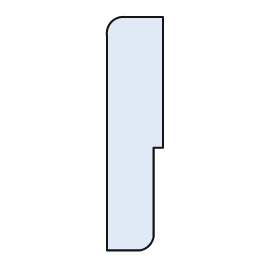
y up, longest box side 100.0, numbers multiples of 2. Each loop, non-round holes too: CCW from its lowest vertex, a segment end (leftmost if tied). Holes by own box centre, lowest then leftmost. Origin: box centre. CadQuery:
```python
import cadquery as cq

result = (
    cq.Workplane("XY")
    .moveTo(-12.0, -50.0)
    .lineTo(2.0, -50.0)
    .threePointArc((6.0, -48.0), (8.0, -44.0))
    .lineTo(8.0, -6.0)
    .lineTo(12.0, -6.0)
    .lineTo(12.0, 50.0)
    .lineTo(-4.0, 50.0)
    .threePointArc((-10.0, 48.0), (-12.0, 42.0))
    .close()
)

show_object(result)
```